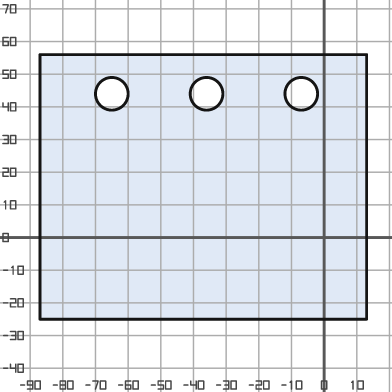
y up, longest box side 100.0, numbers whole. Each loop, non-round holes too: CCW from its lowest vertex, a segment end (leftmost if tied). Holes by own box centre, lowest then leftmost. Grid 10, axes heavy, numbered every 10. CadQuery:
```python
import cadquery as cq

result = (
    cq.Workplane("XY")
    .moveTo(-87.0, -25.0)
    .lineTo(13.0, -25.0)
    .lineTo(13.0, 56.0)
    .lineTo(-87.0, 56.0)
    .close()
    .moveTo(-65.0, 44.0)
    .circle(5.0)
    .moveTo(-36.0, 44.0)
    .circle(5.0)
    .moveTo(-7.0, 44.0)
    .circle(5.0)
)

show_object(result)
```